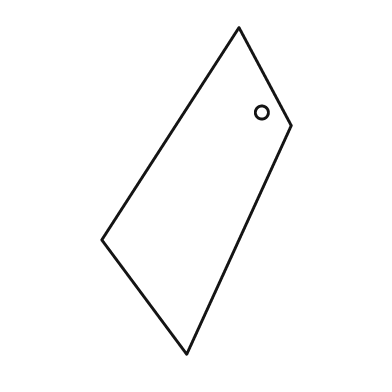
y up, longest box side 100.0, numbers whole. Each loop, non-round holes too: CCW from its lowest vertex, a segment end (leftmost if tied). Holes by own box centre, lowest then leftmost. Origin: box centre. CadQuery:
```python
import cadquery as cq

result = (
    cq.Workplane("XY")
    .moveTo(-3.0, -50.0)
    .lineTo(29.0, 20.0)
    .lineTo(13.0, 50.0)
    .lineTo(-29.0, -15.0)
    .close()
    .moveTo(20.0, 24.0)
    .circle(2.0)
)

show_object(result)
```